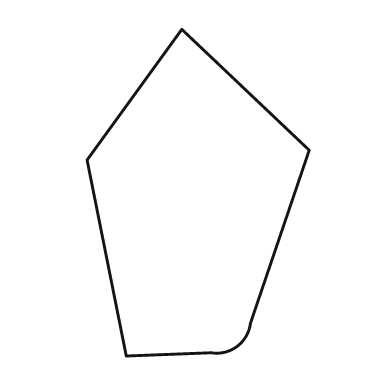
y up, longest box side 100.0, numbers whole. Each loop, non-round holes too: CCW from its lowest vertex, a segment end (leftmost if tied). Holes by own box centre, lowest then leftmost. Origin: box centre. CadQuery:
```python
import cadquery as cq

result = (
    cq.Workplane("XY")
    .moveTo(-22.0, -50.0)
    .lineTo(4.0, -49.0)
    .threePointArc((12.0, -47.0), (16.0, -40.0))
    .lineTo(34.0, 13.0)
    .lineTo(-5.0, 50.0)
    .lineTo(-34.0, 10.0)
    .close()
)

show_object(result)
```